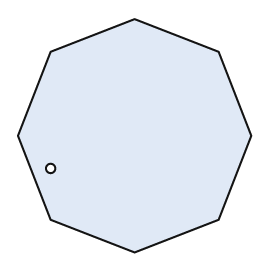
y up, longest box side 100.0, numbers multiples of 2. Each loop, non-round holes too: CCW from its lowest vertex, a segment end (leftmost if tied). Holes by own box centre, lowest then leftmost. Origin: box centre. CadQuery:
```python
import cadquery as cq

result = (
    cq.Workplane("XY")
    .moveTo(0.0, -50.0)
    .lineTo(36.0, -36.0)
    .lineTo(50.0, 0.0)
    .lineTo(36.0, 36.0)
    .lineTo(0.0, 50.0)
    .lineTo(-36.0, 36.0)
    .lineTo(-50.0, 0.0)
    .lineTo(-36.0, -36.0)
    .close()
    .moveTo(-36.0, -14.0)
    .circle(2.0)
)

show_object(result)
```